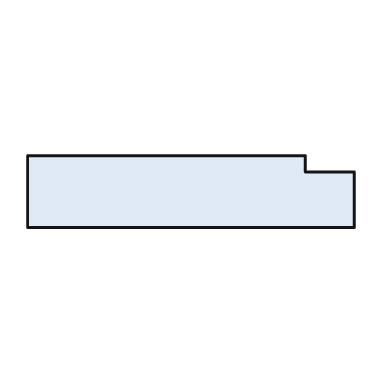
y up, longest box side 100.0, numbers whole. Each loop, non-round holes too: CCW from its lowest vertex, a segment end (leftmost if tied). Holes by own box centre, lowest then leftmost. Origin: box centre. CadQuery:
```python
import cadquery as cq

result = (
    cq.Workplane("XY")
    .moveTo(-50.0, -11.0)
    .lineTo(50.0, -11.0)
    .lineTo(50.0, 6.0)
    .lineTo(35.0, 6.0)
    .lineTo(35.0, 11.0)
    .lineTo(-50.0, 11.0)
    .close()
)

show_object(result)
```